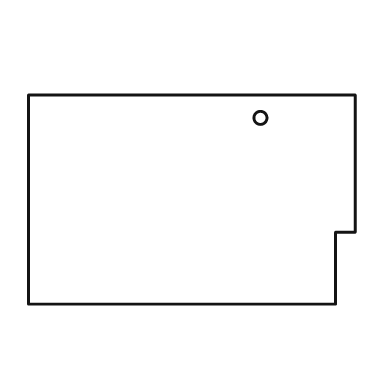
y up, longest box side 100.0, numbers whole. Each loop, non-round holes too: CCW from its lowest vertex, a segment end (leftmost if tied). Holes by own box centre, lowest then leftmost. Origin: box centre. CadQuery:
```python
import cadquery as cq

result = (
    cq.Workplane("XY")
    .moveTo(-50.0, -32.0)
    .lineTo(44.0, -32.0)
    .lineTo(44.0, -10.0)
    .lineTo(50.0, -10.0)
    .lineTo(50.0, 32.0)
    .lineTo(-50.0, 32.0)
    .close()
    .moveTo(21.0, 25.0)
    .circle(2.0)
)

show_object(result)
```